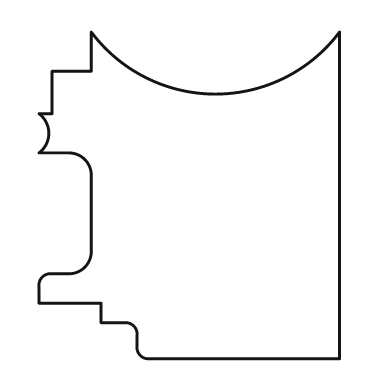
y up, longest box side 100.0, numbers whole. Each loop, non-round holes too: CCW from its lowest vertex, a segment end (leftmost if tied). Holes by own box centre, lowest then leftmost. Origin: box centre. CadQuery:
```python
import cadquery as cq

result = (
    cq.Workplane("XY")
    .moveTo(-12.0, -50.0)
    .lineTo(46.0, -50.0)
    .lineTo(46.0, 50.0)
    .threePointArc((8.0, 31.0), (-30.0, 50.0))
    .lineTo(-30.0, 38.0)
    .lineTo(-42.0, 38.0)
    .lineTo(-42.0, 25.0)
    .lineTo(-46.0, 25.0)
    .threePointArc((-43.0, 19.0), (-46.0, 13.0))
    .lineTo(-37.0, 13.0)
    .threePointArc((-32.0, 11.0), (-30.0, 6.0))
    .lineTo(-30.0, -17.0)
    .threePointArc((-32.0, -22.0), (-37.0, -24.0))
    .lineTo(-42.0, -24.0)
    .threePointArc((-45.0, -25.0), (-46.0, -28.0))
    .lineTo(-46.0, -33.0)
    .lineTo(-27.0, -33.0)
    .lineTo(-27.0, -39.0)
    .lineTo(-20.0, -39.0)
    .threePointArc((-17.0, -40.0), (-16.0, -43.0))
    .lineTo(-16.0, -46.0)
    .threePointArc((-15.0, -49.0), (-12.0, -50.0))
    .close()
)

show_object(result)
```